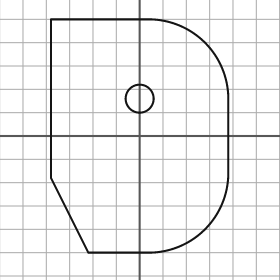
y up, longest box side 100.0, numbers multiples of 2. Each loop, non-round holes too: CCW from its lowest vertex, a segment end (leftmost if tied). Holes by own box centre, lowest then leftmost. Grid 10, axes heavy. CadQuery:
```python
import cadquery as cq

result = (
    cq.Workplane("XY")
    .moveTo(-22.0, -50.0)
    .lineTo(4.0, -50.0)
    .threePointArc((28.0, -40.0), (38.0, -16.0))
    .lineTo(38.0, 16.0)
    .threePointArc((28.0, 40.0), (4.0, 50.0))
    .lineTo(-38.0, 50.0)
    .lineTo(-38.0, -18.0)
    .close()
    .moveTo(0.0, 16.0)
    .circle(6.0)
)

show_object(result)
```